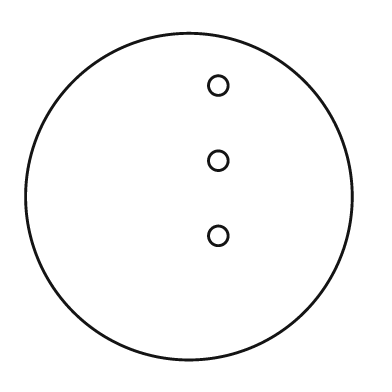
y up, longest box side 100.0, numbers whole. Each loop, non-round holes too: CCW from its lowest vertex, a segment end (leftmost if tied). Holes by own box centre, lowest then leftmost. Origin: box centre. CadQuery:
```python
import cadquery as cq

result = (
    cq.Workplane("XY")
    .moveTo(0.0, 0.0)
    .circle(50.0)
    .moveTo(9.0, -12.0)
    .circle(3.0)
    .moveTo(9.0, 11.0)
    .circle(3.0)
    .moveTo(9.0, 34.0)
    .circle(3.0)
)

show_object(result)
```